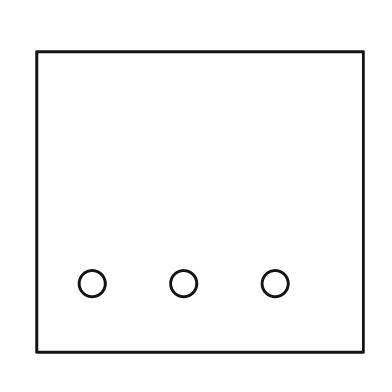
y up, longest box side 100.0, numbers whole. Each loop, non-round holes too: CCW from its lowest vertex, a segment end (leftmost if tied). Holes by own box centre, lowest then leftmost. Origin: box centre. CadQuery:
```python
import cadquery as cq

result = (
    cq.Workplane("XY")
    .moveTo(-50.0, -46.0)
    .lineTo(50.0, -46.0)
    .lineTo(50.0, 46.0)
    .lineTo(-50.0, 46.0)
    .close()
    .moveTo(-33.0, -25.0)
    .circle(4.0)
    .moveTo(-5.0, -25.0)
    .circle(4.0)
    .moveTo(23.0, -25.0)
    .circle(4.0)
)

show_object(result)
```